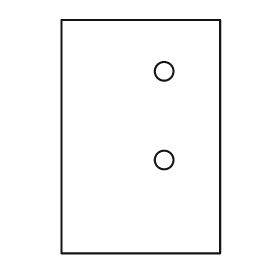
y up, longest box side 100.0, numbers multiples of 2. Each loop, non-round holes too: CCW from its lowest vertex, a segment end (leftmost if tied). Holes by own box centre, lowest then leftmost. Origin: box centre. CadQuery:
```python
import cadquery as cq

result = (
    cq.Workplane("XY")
    .moveTo(-34.0, -50.0)
    .lineTo(34.0, -50.0)
    .lineTo(34.0, 50.0)
    .lineTo(-34.0, 50.0)
    .close()
    .moveTo(10.0, -10.0)
    .circle(4.0)
    .moveTo(10.0, 28.0)
    .circle(4.0)
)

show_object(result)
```